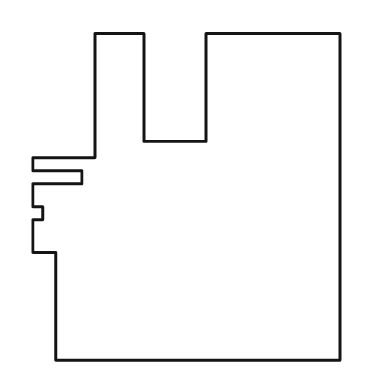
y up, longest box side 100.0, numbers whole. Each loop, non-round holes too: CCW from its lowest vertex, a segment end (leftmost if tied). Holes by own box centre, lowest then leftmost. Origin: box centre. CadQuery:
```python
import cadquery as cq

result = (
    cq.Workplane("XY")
    .moveTo(-40.0, -50.0)
    .lineTo(47.0, -50.0)
    .lineTo(47.0, 50.0)
    .lineTo(6.0, 50.0)
    .lineTo(6.0, 17.0)
    .lineTo(-13.0, 17.0)
    .lineTo(-13.0, 50.0)
    .lineTo(-28.0, 50.0)
    .lineTo(-28.0, 12.0)
    .lineTo(-47.0, 12.0)
    .lineTo(-47.0, 8.0)
    .lineTo(-32.0, 8.0)
    .lineTo(-32.0, 4.0)
    .lineTo(-47.0, 4.0)
    .lineTo(-47.0, -3.0)
    .lineTo(-44.0, -3.0)
    .lineTo(-44.0, -7.0)
    .lineTo(-47.0, -7.0)
    .lineTo(-47.0, -17.0)
    .lineTo(-40.0, -17.0)
    .close()
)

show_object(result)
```